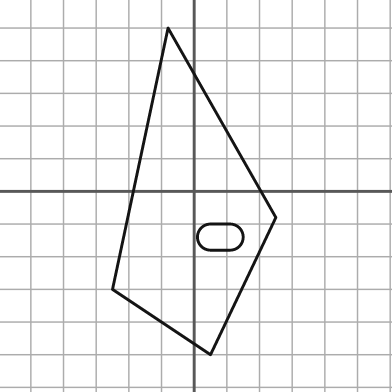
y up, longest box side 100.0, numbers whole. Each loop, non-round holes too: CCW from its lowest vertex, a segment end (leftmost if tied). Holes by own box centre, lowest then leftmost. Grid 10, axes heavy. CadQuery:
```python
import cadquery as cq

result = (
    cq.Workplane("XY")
    .moveTo(5.0, -50.0)
    .lineTo(25.0, -8.0)
    .lineTo(-8.0, 50.0)
    .lineTo(-25.0, -30.0)
    .close()
    .moveTo(5.0, -18.0)
    .lineTo(11.0, -18.0)
    .threePointArc((15.0, -14.0), (11.0, -10.0))
    .lineTo(5.0, -10.0)
    .threePointArc((1.0, -14.0), (5.0, -18.0))
    .close()
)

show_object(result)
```